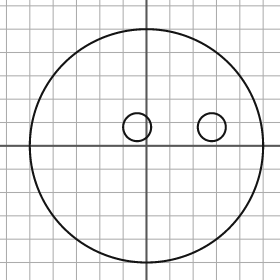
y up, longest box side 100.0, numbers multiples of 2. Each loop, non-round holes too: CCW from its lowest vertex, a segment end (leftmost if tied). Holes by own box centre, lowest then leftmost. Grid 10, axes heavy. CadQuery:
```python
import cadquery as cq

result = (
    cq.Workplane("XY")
    .moveTo(0.0, 0.0)
    .circle(50.0)
    .moveTo(-4.0, 8.0)
    .circle(6.0)
    .moveTo(28.0, 8.0)
    .circle(6.0)
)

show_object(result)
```